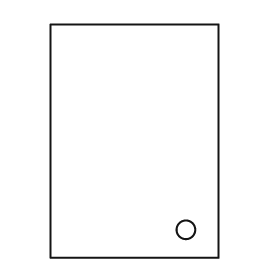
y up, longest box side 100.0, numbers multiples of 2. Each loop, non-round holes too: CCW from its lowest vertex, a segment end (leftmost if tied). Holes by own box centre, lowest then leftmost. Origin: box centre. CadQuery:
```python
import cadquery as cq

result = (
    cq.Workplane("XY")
    .moveTo(-36.0, -50.0)
    .lineTo(36.0, -50.0)
    .lineTo(36.0, 50.0)
    .lineTo(-36.0, 50.0)
    .close()
    .moveTo(22.0, -38.0)
    .circle(4.0)
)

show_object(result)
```